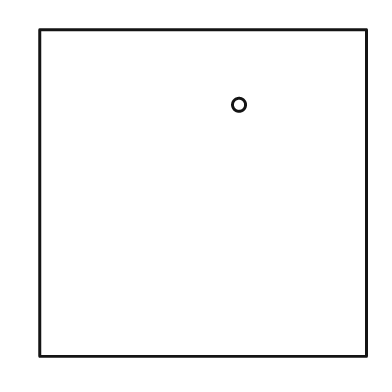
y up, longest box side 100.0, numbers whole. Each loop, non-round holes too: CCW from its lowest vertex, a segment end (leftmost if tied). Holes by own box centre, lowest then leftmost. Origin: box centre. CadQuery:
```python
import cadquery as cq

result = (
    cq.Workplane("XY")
    .moveTo(-50.0, -50.0)
    .lineTo(50.0, -50.0)
    .lineTo(50.0, 50.0)
    .lineTo(-50.0, 50.0)
    .close()
    .moveTo(11.0, 27.0)
    .circle(2.0)
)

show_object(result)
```